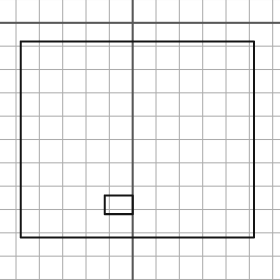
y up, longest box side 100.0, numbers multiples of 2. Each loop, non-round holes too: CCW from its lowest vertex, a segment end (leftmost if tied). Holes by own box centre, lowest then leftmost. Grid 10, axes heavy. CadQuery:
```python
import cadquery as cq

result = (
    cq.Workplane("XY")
    .moveTo(-48.0, -92.0)
    .lineTo(52.0, -92.0)
    .lineTo(52.0, -8.0)
    .lineTo(-48.0, -8.0)
    .close()
    .moveTo(-12.0, -82.0)
    .lineTo(0.0, -82.0)
    .lineTo(0.0, -74.0)
    .lineTo(-12.0, -74.0)
    .close()
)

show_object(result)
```